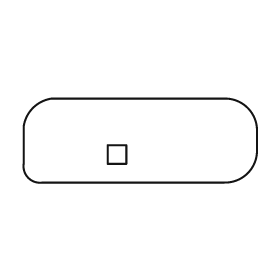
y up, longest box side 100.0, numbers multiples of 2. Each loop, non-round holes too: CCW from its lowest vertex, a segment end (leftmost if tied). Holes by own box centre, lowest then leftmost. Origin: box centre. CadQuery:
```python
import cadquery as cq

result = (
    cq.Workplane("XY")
    .moveTo(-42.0, -18.0)
    .lineTo(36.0, -18.0)
    .threePointArc((46.0, -14.0), (50.0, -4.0))
    .lineTo(50.0, 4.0)
    .threePointArc((46.0, 14.0), (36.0, 18.0))
    .lineTo(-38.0, 18.0)
    .threePointArc((-46.0, 14.0), (-50.0, 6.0))
    .lineTo(-50.0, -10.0)
    .threePointArc((-48.0, -16.0), (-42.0, -18.0))
    .close()
    .moveTo(-14.0, -10.0)
    .lineTo(-6.0, -10.0)
    .lineTo(-6.0, -2.0)
    .lineTo(-14.0, -2.0)
    .close()
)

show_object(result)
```